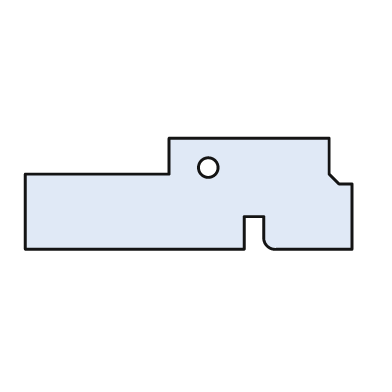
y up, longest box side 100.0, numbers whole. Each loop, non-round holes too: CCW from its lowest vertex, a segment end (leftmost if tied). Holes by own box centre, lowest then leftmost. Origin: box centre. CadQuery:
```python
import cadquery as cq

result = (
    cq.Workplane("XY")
    .moveTo(-50.0, -17.0)
    .lineTo(17.0, -17.0)
    .lineTo(17.0, -7.0)
    .lineTo(23.0, -7.0)
    .lineTo(23.0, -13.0)
    .threePointArc((24.0, -16.0), (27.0, -17.0))
    .lineTo(50.0, -17.0)
    .lineTo(50.0, 3.0)
    .lineTo(46.0, 3.0)
    .lineTo(43.0, 6.0)
    .lineTo(43.0, 17.0)
    .lineTo(-6.0, 17.0)
    .lineTo(-6.0, 6.0)
    .lineTo(-50.0, 6.0)
    .close()
    .moveTo(6.0, 8.0)
    .circle(3.0)
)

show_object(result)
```